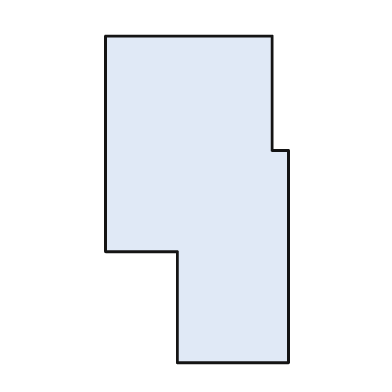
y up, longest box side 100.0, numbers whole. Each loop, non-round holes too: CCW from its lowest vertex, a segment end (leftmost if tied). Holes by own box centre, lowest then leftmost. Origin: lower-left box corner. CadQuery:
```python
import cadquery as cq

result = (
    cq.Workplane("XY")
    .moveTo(22.0, 0.0)
    .lineTo(56.0, 0.0)
    .lineTo(56.0, 65.0)
    .lineTo(51.0, 65.0)
    .lineTo(51.0, 100.0)
    .lineTo(0.0, 100.0)
    .lineTo(0.0, 34.0)
    .lineTo(22.0, 34.0)
    .close()
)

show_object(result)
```